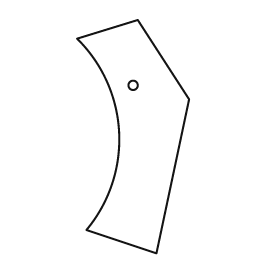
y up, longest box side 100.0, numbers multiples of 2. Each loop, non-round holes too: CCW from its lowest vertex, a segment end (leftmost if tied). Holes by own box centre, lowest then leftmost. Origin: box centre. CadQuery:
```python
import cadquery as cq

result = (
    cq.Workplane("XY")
    .moveTo(10.0, -50.0)
    .lineTo(24.0, 16.0)
    .lineTo(2.0, 50.0)
    .lineTo(-24.0, 42.0)
    .threePointArc((-6.0, 2.0), (-20.0, -40.0))
    .close()
    .moveTo(0.0, 22.0)
    .circle(2.0)
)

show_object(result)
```